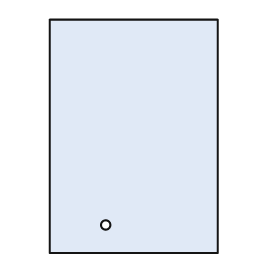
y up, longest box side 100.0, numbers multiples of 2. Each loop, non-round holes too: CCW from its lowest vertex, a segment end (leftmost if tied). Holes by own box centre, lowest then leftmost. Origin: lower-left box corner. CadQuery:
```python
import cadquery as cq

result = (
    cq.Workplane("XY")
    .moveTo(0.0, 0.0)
    .lineTo(72.0, 0.0)
    .lineTo(72.0, 100.0)
    .lineTo(0.0, 100.0)
    .close()
    .moveTo(24.0, 12.0)
    .circle(2.0)
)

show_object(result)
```